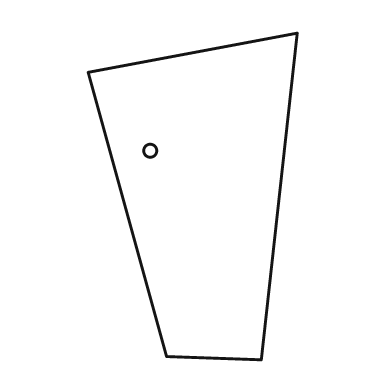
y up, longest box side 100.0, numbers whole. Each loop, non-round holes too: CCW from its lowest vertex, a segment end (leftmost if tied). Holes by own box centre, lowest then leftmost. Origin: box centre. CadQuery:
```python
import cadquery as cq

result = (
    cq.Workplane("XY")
    .moveTo(21.0, -50.0)
    .lineTo(32.0, 50.0)
    .lineTo(-32.0, 38.0)
    .lineTo(-8.0, -49.0)
    .close()
    .moveTo(-13.0, 14.0)
    .circle(2.0)
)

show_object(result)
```